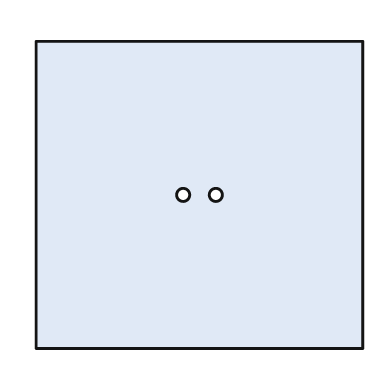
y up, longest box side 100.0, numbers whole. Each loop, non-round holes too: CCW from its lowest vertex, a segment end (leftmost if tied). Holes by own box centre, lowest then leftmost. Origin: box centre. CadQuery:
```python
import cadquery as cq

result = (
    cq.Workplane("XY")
    .moveTo(-50.0, -47.0)
    .lineTo(50.0, -47.0)
    .lineTo(50.0, 47.0)
    .lineTo(-50.0, 47.0)
    .close()
    .moveTo(-5.0, 0.0)
    .circle(2.0)
    .moveTo(5.0, 0.0)
    .circle(2.0)
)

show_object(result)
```